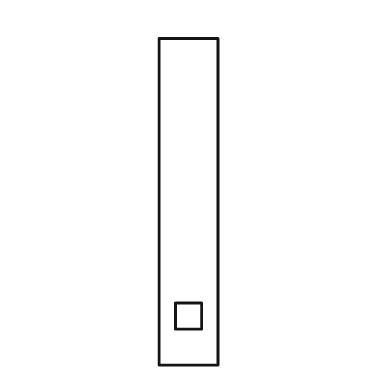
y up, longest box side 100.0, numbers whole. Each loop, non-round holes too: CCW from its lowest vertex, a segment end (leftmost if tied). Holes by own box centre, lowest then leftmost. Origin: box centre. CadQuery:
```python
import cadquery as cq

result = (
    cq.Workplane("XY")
    .moveTo(-9.0, -50.0)
    .lineTo(9.0, -50.0)
    .lineTo(9.0, 50.0)
    .lineTo(-9.0, 50.0)
    .close()
    .moveTo(-4.0, -39.0)
    .lineTo(4.0, -39.0)
    .lineTo(4.0, -31.0)
    .lineTo(-4.0, -31.0)
    .close()
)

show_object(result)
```